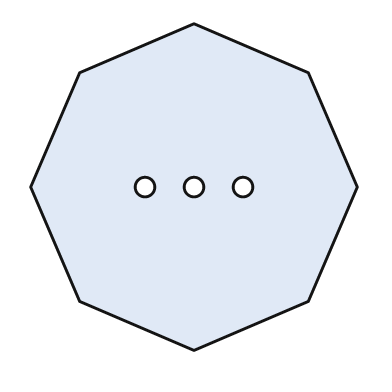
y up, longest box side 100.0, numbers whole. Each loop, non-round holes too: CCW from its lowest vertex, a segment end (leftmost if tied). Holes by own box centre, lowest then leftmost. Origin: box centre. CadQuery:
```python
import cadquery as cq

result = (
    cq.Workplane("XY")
    .moveTo(0.0, -50.0)
    .lineTo(35.0, -35.0)
    .lineTo(50.0, 0.0)
    .lineTo(35.0, 35.0)
    .lineTo(0.0, 50.0)
    .lineTo(-35.0, 35.0)
    .lineTo(-50.0, 0.0)
    .lineTo(-35.0, -35.0)
    .close()
    .moveTo(-15.0, 0.0)
    .circle(3.0)
    .moveTo(0.0, 0.0)
    .circle(3.0)
    .moveTo(15.0, 0.0)
    .circle(3.0)
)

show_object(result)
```